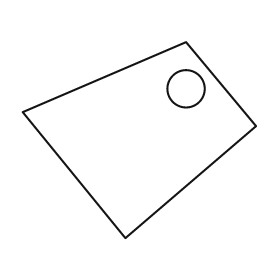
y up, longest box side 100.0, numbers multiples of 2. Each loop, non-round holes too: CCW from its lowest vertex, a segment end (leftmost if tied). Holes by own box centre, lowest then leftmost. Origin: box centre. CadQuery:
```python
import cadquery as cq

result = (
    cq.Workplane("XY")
    .moveTo(-6.0, -42.0)
    .lineTo(50.0, 6.0)
    .lineTo(20.0, 42.0)
    .lineTo(-50.0, 12.0)
    .close()
    .moveTo(20.0, 22.0)
    .circle(8.0)
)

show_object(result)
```